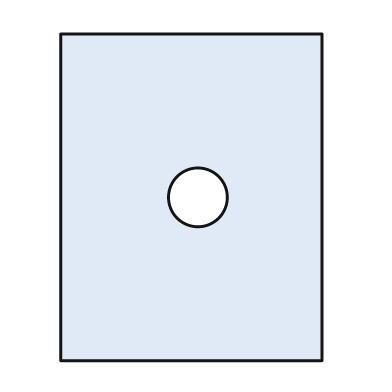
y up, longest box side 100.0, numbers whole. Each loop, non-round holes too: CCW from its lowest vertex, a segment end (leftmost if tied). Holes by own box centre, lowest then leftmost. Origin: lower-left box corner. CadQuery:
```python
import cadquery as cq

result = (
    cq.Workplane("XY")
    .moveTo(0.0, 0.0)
    .lineTo(80.0, 0.0)
    .lineTo(80.0, 100.0)
    .lineTo(0.0, 100.0)
    .close()
    .moveTo(42.0, 50.0)
    .circle(9.0)
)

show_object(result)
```